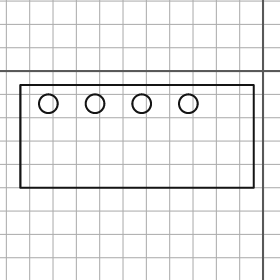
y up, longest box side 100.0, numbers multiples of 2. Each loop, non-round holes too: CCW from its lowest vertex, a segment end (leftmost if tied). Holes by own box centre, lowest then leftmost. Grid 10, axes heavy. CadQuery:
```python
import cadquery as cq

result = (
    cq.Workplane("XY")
    .moveTo(-104.0, -50.0)
    .lineTo(-4.0, -50.0)
    .lineTo(-4.0, -6.0)
    .lineTo(-104.0, -6.0)
    .close()
    .moveTo(-92.0, -14.0)
    .circle(4.0)
    .moveTo(-72.0, -14.0)
    .circle(4.0)
    .moveTo(-52.0, -14.0)
    .circle(4.0)
    .moveTo(-32.0, -14.0)
    .circle(4.0)
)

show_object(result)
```